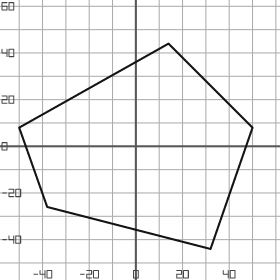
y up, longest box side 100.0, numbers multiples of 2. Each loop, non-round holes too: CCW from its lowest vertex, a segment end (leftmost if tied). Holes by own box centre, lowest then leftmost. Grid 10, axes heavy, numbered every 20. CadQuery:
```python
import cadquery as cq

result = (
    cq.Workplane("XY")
    .moveTo(32.0, -44.0)
    .lineTo(50.0, 8.0)
    .lineTo(14.0, 44.0)
    .lineTo(-50.0, 8.0)
    .lineTo(-38.0, -26.0)
    .close()
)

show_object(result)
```